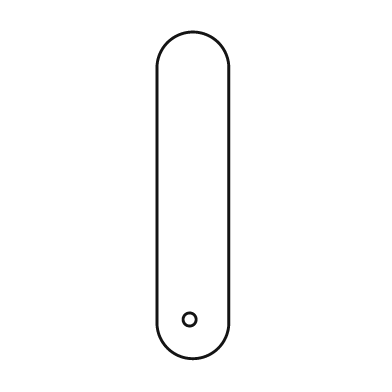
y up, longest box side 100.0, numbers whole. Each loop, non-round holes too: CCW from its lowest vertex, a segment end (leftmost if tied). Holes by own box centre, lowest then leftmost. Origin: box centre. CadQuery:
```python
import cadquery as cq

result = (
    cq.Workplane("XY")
    .moveTo(-11.0, -39.0)
    .threePointArc((0.0, -50.0), (11.0, -39.0))
    .lineTo(11.0, 39.0)
    .threePointArc((0.0, 50.0), (-11.0, 39.0))
    .close()
    .moveTo(-1.0, -38.0)
    .circle(2.0)
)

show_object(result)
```